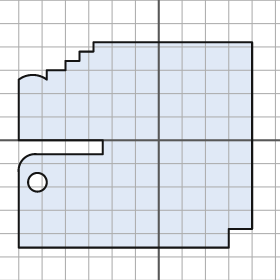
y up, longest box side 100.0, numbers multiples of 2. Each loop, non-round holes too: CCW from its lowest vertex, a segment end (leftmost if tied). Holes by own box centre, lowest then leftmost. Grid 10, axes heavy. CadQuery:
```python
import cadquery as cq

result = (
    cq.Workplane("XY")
    .moveTo(-60.0, -46.0)
    .lineTo(30.0, -46.0)
    .lineTo(30.0, -38.0)
    .lineTo(40.0, -38.0)
    .lineTo(40.0, 42.0)
    .lineTo(-28.0, 42.0)
    .lineTo(-28.0, 38.0)
    .lineTo(-34.0, 38.0)
    .lineTo(-34.0, 34.0)
    .lineTo(-40.0, 34.0)
    .lineTo(-40.0, 30.0)
    .lineTo(-48.0, 30.0)
    .lineTo(-48.0, 26.0)
    .threePointArc((-54.0, 28.0), (-60.0, 26.0))
    .lineTo(-60.0, 0.0)
    .lineTo(-24.0, 0.0)
    .lineTo(-24.0, -6.0)
    .lineTo(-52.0, -6.0)
    .threePointArc((-58.0, -8.0), (-60.0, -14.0))
    .close()
    .moveTo(-52.0, -18.0)
    .circle(4.0)
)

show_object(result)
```